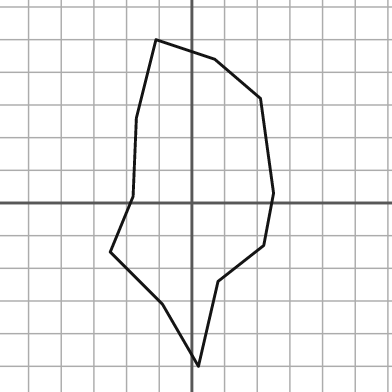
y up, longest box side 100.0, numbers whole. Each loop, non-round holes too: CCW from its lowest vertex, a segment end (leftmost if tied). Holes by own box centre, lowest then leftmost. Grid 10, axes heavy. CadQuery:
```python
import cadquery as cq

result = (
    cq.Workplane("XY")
    .moveTo(2.0, -50.0)
    .lineTo(8.0, -24.0)
    .lineTo(22.0, -13.0)
    .lineTo(25.0, 3.0)
    .lineTo(21.0, 32.0)
    .lineTo(7.0, 44.0)
    .lineTo(-11.0, 50.0)
    .lineTo(-17.0, 26.0)
    .lineTo(-18.0, 2.0)
    .lineTo(-25.0, -15.0)
    .lineTo(-9.0, -31.0)
    .close()
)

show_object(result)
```